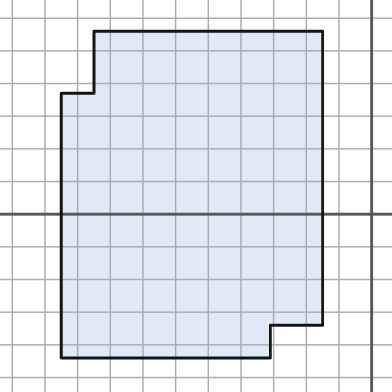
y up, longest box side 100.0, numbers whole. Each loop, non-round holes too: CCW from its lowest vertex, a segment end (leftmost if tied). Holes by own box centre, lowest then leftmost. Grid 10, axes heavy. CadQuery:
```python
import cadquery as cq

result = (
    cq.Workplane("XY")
    .moveTo(-95.0, -44.0)
    .lineTo(-31.0, -44.0)
    .lineTo(-31.0, -34.0)
    .lineTo(-15.0, -34.0)
    .lineTo(-15.0, 56.0)
    .lineTo(-85.0, 56.0)
    .lineTo(-85.0, 37.0)
    .lineTo(-95.0, 37.0)
    .close()
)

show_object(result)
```